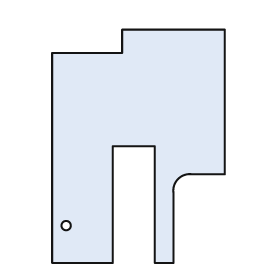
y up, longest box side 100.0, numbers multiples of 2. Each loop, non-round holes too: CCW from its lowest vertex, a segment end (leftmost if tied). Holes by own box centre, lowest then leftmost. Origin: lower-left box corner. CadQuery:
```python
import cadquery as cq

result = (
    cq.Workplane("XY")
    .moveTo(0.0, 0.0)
    .lineTo(26.0, 0.0)
    .lineTo(26.0, 50.0)
    .lineTo(44.0, 50.0)
    .lineTo(44.0, 0.0)
    .lineTo(52.0, 0.0)
    .lineTo(52.0, 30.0)
    .threePointArc((54.0, 36.0), (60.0, 38.0))
    .lineTo(74.0, 38.0)
    .lineTo(74.0, 100.0)
    .lineTo(30.0, 100.0)
    .lineTo(30.0, 90.0)
    .lineTo(0.0, 90.0)
    .close()
    .moveTo(6.0, 16.0)
    .circle(2.0)
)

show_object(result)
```